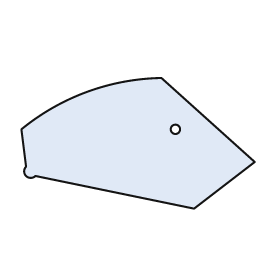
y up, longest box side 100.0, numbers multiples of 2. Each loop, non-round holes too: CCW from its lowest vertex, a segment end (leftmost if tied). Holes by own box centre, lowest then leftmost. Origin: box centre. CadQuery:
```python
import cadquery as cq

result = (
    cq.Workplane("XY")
    .moveTo(24.0, -28.0)
    .lineTo(50.0, -8.0)
    .lineTo(10.0, 28.0)
    .threePointArc((-22.0, 22.0), (-50.0, 6.0))
    .lineTo(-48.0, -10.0)
    .threePointArc((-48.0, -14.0), (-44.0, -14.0))
    .close()
    .moveTo(16.0, 6.0)
    .circle(2.0)
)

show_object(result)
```